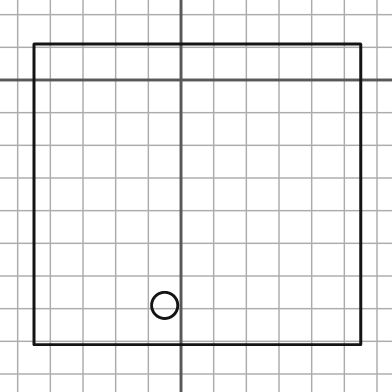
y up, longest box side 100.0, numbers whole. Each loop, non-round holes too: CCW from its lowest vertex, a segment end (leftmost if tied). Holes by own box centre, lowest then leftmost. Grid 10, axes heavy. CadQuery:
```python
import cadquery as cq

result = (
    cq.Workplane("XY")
    .moveTo(-45.0, -81.0)
    .lineTo(55.0, -81.0)
    .lineTo(55.0, 11.0)
    .lineTo(-45.0, 11.0)
    .close()
    .moveTo(-5.0, -69.0)
    .circle(4.0)
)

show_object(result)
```